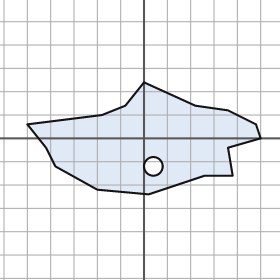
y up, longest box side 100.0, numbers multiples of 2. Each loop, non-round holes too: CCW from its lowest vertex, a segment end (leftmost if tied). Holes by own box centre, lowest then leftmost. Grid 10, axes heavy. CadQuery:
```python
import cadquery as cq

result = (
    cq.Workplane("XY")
    .moveTo(2.0, -24.0)
    .lineTo(26.0, -16.0)
    .lineTo(38.0, -16.0)
    .lineTo(36.0, -4.0)
    .lineTo(50.0, 0.0)
    .lineTo(48.0, 6.0)
    .lineTo(36.0, 12.0)
    .lineTo(22.0, 14.0)
    .lineTo(0.0, 24.0)
    .lineTo(-8.0, 14.0)
    .lineTo(-18.0, 10.0)
    .lineTo(-50.0, 6.0)
    .lineTo(-42.0, -4.0)
    .lineTo(-38.0, -12.0)
    .lineTo(-20.0, -22.0)
    .close()
    .moveTo(4.0, -12.0)
    .circle(4.0)
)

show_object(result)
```